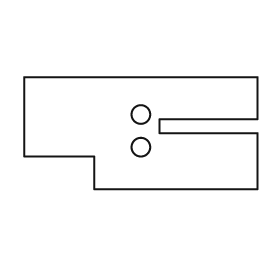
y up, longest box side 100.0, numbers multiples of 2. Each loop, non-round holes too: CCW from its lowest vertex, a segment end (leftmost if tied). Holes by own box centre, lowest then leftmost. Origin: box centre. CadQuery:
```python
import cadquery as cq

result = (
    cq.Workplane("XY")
    .moveTo(-20.0, -24.0)
    .lineTo(50.0, -24.0)
    .lineTo(50.0, 0.0)
    .lineTo(8.0, 0.0)
    .lineTo(8.0, 6.0)
    .lineTo(50.0, 6.0)
    .lineTo(50.0, 24.0)
    .lineTo(-50.0, 24.0)
    .lineTo(-50.0, -10.0)
    .lineTo(-20.0, -10.0)
    .close()
    .moveTo(0.0, -6.0)
    .circle(4.0)
    .moveTo(0.0, 8.0)
    .circle(4.0)
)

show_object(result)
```